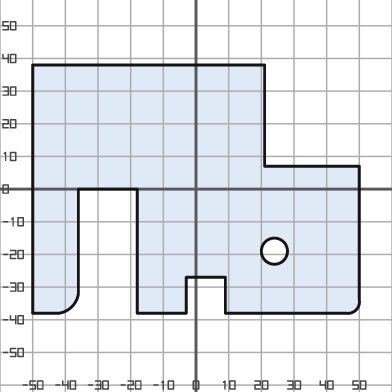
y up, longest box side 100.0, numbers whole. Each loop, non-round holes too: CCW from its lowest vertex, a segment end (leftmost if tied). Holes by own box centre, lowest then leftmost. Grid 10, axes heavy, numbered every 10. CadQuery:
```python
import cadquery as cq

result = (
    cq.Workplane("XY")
    .moveTo(-50.0, -38.0)
    .lineTo(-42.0, -38.0)
    .threePointArc((-38.0, -36.0), (-36.0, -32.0))
    .lineTo(-36.0, 0.0)
    .lineTo(-18.0, 0.0)
    .lineTo(-18.0, -38.0)
    .lineTo(-3.0, -38.0)
    .lineTo(-3.0, -27.0)
    .lineTo(9.0, -27.0)
    .lineTo(9.0, -38.0)
    .lineTo(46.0, -38.0)
    .threePointArc((49.0, -37.0), (50.0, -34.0))
    .lineTo(50.0, 7.0)
    .lineTo(21.0, 7.0)
    .lineTo(21.0, 38.0)
    .lineTo(-50.0, 38.0)
    .close()
    .moveTo(24.0, -19.0)
    .circle(4.0)
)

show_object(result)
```